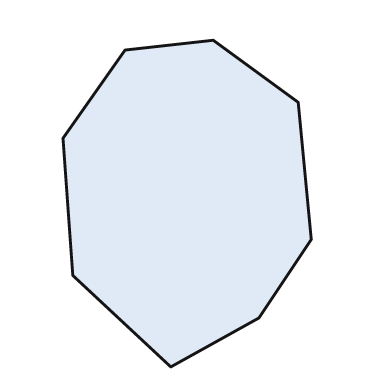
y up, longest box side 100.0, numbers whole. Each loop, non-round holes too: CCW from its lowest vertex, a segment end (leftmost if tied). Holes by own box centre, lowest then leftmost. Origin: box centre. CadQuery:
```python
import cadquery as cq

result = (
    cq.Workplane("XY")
    .moveTo(-5.0, -50.0)
    .lineTo(22.0, -35.0)
    .lineTo(38.0, -11.0)
    .lineTo(34.0, 31.0)
    .lineTo(8.0, 50.0)
    .lineTo(-19.0, 47.0)
    .lineTo(-38.0, 20.0)
    .lineTo(-35.0, -22.0)
    .close()
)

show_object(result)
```